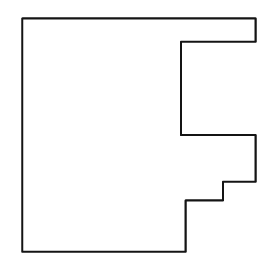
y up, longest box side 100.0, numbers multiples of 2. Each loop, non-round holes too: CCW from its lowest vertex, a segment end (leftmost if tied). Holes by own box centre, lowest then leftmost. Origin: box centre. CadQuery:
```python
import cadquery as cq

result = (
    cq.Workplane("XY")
    .moveTo(-50.0, -50.0)
    .lineTo(20.0, -50.0)
    .lineTo(20.0, -28.0)
    .lineTo(36.0, -28.0)
    .lineTo(36.0, -20.0)
    .lineTo(50.0, -20.0)
    .lineTo(50.0, 0.0)
    .lineTo(18.0, 0.0)
    .lineTo(18.0, 40.0)
    .lineTo(50.0, 40.0)
    .lineTo(50.0, 50.0)
    .lineTo(-50.0, 50.0)
    .close()
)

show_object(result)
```